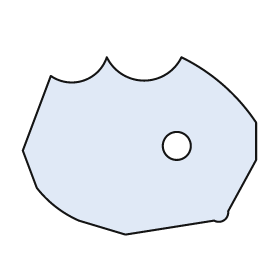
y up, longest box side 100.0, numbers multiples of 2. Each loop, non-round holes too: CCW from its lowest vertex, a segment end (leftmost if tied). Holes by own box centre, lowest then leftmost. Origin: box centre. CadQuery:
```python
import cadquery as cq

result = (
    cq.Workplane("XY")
    .moveTo(-6.0, -38.0)
    .lineTo(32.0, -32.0)
    .threePointArc((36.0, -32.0), (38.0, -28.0))
    .lineTo(50.0, -6.0)
    .lineTo(50.0, 10.0)
    .threePointArc((36.0, 26.0), (18.0, 38.0))
    .threePointArc((2.0, 28.0), (-14.0, 38.0))
    .threePointArc((-24.0, 28.0), (-38.0, 30.0))
    .lineTo(-50.0, -2.0)
    .lineTo(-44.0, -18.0)
    .threePointArc((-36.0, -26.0), (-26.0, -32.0))
    .close()
    .moveTo(16.0, 0.0)
    .circle(6.0)
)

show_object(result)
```